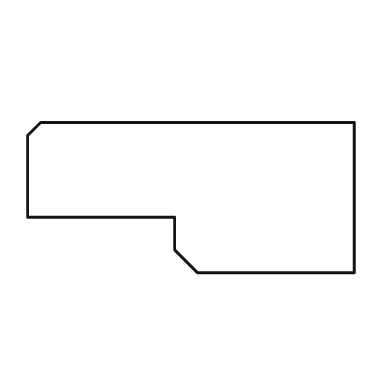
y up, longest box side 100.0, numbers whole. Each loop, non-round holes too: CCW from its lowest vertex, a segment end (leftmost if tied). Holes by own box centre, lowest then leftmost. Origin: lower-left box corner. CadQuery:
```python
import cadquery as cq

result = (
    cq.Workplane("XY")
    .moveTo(52.0, 0.0)
    .lineTo(100.0, 0.0)
    .lineTo(100.0, 46.0)
    .lineTo(4.0, 46.0)
    .lineTo(0.0, 42.0)
    .lineTo(0.0, 17.0)
    .lineTo(45.0, 17.0)
    .lineTo(45.0, 7.0)
    .close()
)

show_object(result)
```